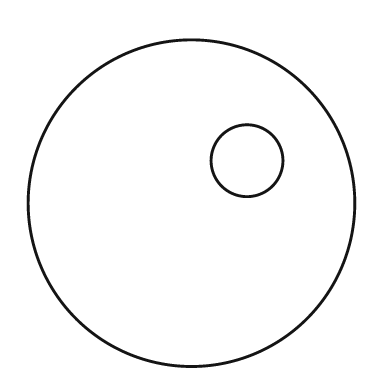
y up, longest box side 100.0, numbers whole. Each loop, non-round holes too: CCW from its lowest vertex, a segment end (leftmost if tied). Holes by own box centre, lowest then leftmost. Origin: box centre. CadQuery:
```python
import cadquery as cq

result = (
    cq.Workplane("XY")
    .moveTo(0.0, 0.0)
    .circle(50.0)
    .moveTo(17.0, 13.0)
    .circle(11.0)
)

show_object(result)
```